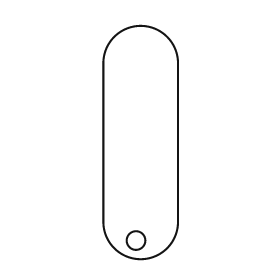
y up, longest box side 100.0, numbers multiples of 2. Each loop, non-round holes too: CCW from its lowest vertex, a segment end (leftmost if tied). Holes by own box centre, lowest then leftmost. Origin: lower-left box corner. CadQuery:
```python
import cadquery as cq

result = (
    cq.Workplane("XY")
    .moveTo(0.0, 16.0)
    .threePointArc((16.0, 0.0), (32.0, 16.0))
    .lineTo(32.0, 84.0)
    .threePointArc((16.0, 100.0), (0.0, 84.0))
    .close()
    .moveTo(14.0, 8.0)
    .circle(4.0)
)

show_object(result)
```